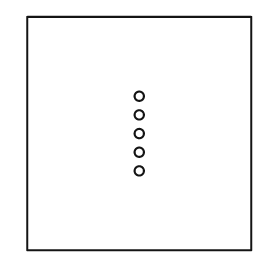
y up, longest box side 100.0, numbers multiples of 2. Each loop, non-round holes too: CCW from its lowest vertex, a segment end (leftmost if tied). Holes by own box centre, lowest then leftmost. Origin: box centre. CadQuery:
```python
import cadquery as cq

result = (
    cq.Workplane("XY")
    .moveTo(-48.0, -50.0)
    .lineTo(48.0, -50.0)
    .lineTo(48.0, 50.0)
    .lineTo(-48.0, 50.0)
    .close()
    .moveTo(0.0, -16.0)
    .circle(2.0)
    .moveTo(0.0, -8.0)
    .circle(2.0)
    .moveTo(0.0, 0.0)
    .circle(2.0)
    .moveTo(0.0, 8.0)
    .circle(2.0)
    .moveTo(0.0, 16.0)
    .circle(2.0)
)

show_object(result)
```